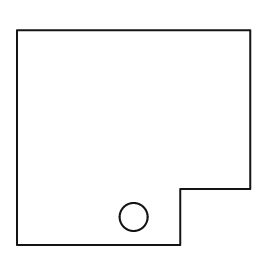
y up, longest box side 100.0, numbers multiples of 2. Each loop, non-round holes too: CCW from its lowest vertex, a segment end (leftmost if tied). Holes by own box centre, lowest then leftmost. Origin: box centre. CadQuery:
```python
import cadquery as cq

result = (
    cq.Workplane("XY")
    .moveTo(-50.0, -46.0)
    .lineTo(20.0, -46.0)
    .lineTo(20.0, -22.0)
    .lineTo(50.0, -22.0)
    .lineTo(50.0, 46.0)
    .lineTo(-50.0, 46.0)
    .close()
    .moveTo(0.0, -34.0)
    .circle(6.0)
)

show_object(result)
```